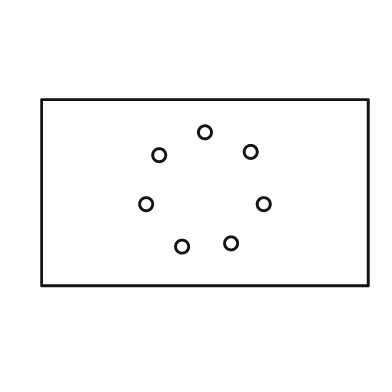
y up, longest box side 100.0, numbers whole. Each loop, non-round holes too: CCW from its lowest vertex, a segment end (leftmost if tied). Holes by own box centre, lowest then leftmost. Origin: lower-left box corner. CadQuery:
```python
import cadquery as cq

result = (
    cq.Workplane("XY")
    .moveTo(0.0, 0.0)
    .lineTo(100.0, 0.0)
    .lineTo(100.0, 57.0)
    .lineTo(0.0, 57.0)
    .close()
    .moveTo(43.0, 12.0)
    .circle(2.0)
    .moveTo(58.0, 13.0)
    .circle(2.0)
    .moveTo(32.0, 25.0)
    .circle(2.0)
    .moveTo(68.0, 25.0)
    .circle(2.0)
    .moveTo(36.0, 40.0)
    .circle(2.0)
    .moveTo(64.0, 41.0)
    .circle(2.0)
    .moveTo(50.0, 47.0)
    .circle(2.0)
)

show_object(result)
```